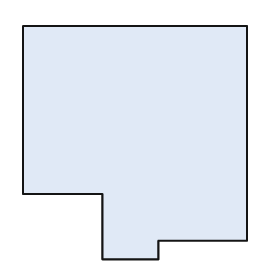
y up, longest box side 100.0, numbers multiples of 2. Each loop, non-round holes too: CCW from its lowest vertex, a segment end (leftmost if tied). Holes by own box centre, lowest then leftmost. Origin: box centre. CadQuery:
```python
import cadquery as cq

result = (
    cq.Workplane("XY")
    .moveTo(-14.0, -50.0)
    .lineTo(10.0, -50.0)
    .lineTo(10.0, -42.0)
    .lineTo(48.0, -42.0)
    .lineTo(48.0, 50.0)
    .lineTo(-48.0, 50.0)
    .lineTo(-48.0, -22.0)
    .lineTo(-14.0, -22.0)
    .close()
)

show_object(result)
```